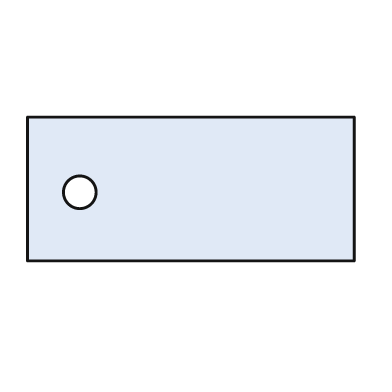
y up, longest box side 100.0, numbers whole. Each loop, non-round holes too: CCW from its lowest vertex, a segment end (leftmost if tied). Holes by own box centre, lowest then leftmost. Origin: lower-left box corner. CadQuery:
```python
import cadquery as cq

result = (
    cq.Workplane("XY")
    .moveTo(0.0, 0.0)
    .lineTo(100.0, 0.0)
    .lineTo(100.0, 44.0)
    .lineTo(0.0, 44.0)
    .close()
    .moveTo(16.0, 21.0)
    .circle(5.0)
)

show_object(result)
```